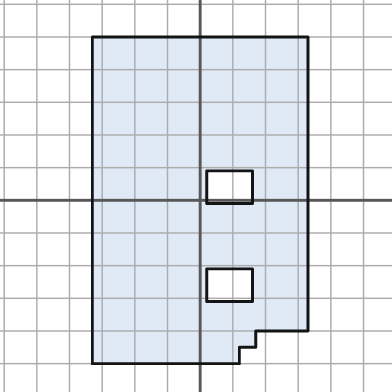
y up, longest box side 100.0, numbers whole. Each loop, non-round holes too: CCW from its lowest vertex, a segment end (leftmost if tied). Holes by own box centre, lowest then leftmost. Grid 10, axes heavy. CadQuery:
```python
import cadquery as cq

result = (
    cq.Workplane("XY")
    .moveTo(-33.0, -50.0)
    .lineTo(12.0, -50.0)
    .lineTo(12.0, -45.0)
    .lineTo(17.0, -45.0)
    .lineTo(17.0, -40.0)
    .lineTo(33.0, -40.0)
    .lineTo(33.0, 50.0)
    .lineTo(-33.0, 50.0)
    .close()
    .moveTo(2.0, -31.0)
    .lineTo(16.0, -31.0)
    .lineTo(16.0, -21.0)
    .lineTo(2.0, -21.0)
    .close()
    .moveTo(2.0, -1.0)
    .lineTo(16.0, -1.0)
    .lineTo(16.0, 9.0)
    .lineTo(2.0, 9.0)
    .close()
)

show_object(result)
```